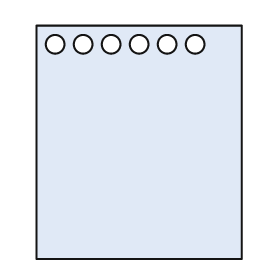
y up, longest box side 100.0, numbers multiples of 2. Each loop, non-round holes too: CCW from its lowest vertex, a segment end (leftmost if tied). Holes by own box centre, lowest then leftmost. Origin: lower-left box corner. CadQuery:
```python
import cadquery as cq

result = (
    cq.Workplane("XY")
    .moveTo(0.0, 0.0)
    .lineTo(88.0, 0.0)
    .lineTo(88.0, 100.0)
    .lineTo(0.0, 100.0)
    .close()
    .moveTo(8.0, 92.0)
    .circle(4.0)
    .moveTo(20.0, 92.0)
    .circle(4.0)
    .moveTo(32.0, 92.0)
    .circle(4.0)
    .moveTo(44.0, 92.0)
    .circle(4.0)
    .moveTo(56.0, 92.0)
    .circle(4.0)
    .moveTo(68.0, 92.0)
    .circle(4.0)
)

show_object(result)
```